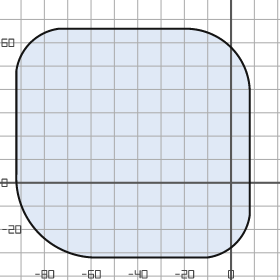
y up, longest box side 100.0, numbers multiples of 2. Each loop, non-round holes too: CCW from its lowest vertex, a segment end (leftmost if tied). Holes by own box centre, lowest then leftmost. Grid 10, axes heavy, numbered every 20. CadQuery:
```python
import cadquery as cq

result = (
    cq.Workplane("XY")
    .moveTo(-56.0, -32.0)
    .lineTo(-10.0, -32.0)
    .threePointArc((2.0, -26.0), (8.0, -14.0))
    .lineTo(8.0, 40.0)
    .threePointArc((0.0, 58.0), (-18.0, 66.0))
    .lineTo(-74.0, 66.0)
    .threePointArc((-86.0, 60.0), (-92.0, 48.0))
    .lineTo(-92.0, 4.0)
    .threePointArc((-82.0, -22.0), (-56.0, -32.0))
    .close()
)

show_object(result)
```